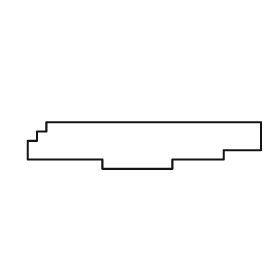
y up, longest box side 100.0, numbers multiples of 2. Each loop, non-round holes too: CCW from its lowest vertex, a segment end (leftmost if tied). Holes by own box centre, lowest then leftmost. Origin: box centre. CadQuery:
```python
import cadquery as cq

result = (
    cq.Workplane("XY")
    .moveTo(-18.0, -10.0)
    .lineTo(12.0, -10.0)
    .lineTo(12.0, -6.0)
    .lineTo(34.0, -6.0)
    .lineTo(34.0, -2.0)
    .lineTo(50.0, -2.0)
    .lineTo(50.0, 10.0)
    .lineTo(-42.0, 10.0)
    .lineTo(-42.0, 6.0)
    .lineTo(-46.0, 6.0)
    .lineTo(-46.0, 2.0)
    .lineTo(-50.0, 2.0)
    .lineTo(-50.0, -6.0)
    .lineTo(-18.0, -6.0)
    .close()
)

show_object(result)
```